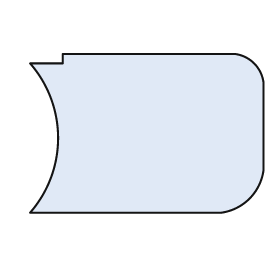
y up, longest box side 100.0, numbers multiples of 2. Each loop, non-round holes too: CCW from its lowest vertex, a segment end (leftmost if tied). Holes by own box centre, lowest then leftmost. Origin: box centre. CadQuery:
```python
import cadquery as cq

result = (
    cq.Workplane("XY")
    .moveTo(-50.0, -34.0)
    .lineTo(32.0, -34.0)
    .threePointArc((44.0, -28.0), (50.0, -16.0))
    .lineTo(50.0, 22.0)
    .threePointArc((46.0, 30.0), (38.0, 34.0))
    .lineTo(-36.0, 34.0)
    .lineTo(-36.0, 30.0)
    .lineTo(-50.0, 30.0)
    .threePointArc((-38.0, -2.0), (-50.0, -34.0))
    .close()
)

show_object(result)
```